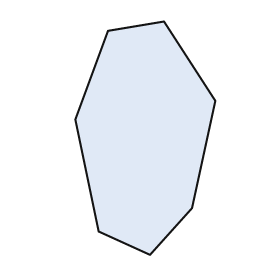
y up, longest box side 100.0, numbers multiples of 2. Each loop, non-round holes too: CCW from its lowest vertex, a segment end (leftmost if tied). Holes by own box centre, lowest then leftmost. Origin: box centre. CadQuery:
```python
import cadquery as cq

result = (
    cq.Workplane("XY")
    .moveTo(2.0, -50.0)
    .lineTo(20.0, -30.0)
    .lineTo(30.0, 16.0)
    .lineTo(8.0, 50.0)
    .lineTo(-16.0, 46.0)
    .lineTo(-30.0, 8.0)
    .lineTo(-20.0, -40.0)
    .close()
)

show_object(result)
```